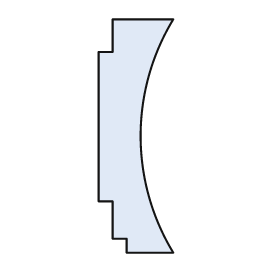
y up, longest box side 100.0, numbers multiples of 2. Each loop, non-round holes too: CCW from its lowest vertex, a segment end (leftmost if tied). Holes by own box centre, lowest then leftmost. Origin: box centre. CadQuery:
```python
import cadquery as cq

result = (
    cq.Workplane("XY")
    .moveTo(-4.0, -50.0)
    .lineTo(16.0, -50.0)
    .threePointArc((2.0, 0.0), (16.0, 50.0))
    .lineTo(-10.0, 50.0)
    .lineTo(-10.0, 36.0)
    .lineTo(-16.0, 36.0)
    .lineTo(-16.0, -28.0)
    .lineTo(-10.0, -28.0)
    .lineTo(-10.0, -44.0)
    .lineTo(-4.0, -44.0)
    .close()
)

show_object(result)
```